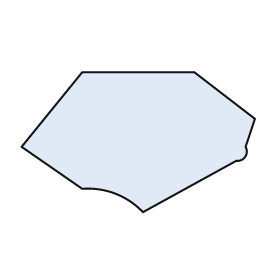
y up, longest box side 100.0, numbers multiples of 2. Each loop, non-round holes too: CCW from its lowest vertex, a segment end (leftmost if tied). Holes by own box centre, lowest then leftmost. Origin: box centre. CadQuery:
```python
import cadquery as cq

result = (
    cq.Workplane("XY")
    .moveTo(2.0, -30.0)
    .lineTo(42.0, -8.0)
    .threePointArc((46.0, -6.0), (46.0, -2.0))
    .lineTo(50.0, 10.0)
    .lineTo(24.0, 30.0)
    .lineTo(-24.0, 30.0)
    .lineTo(-50.0, -2.0)
    .lineTo(-24.0, -20.0)
    .threePointArc((-10.0, -22.0), (2.0, -30.0))
    .close()
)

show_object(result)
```